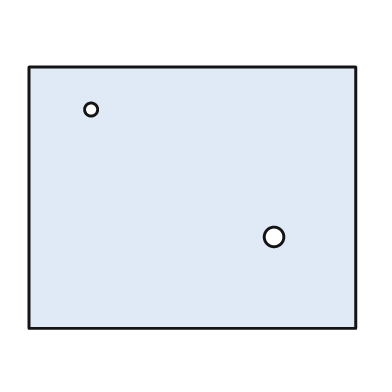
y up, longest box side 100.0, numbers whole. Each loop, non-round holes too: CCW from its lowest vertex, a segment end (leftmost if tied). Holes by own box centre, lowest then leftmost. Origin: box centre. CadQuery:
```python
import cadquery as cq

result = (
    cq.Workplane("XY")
    .moveTo(-50.0, -40.0)
    .lineTo(50.0, -40.0)
    .lineTo(50.0, 40.0)
    .lineTo(-50.0, 40.0)
    .close()
    .moveTo(25.0, -12.0)
    .circle(3.0)
    .moveTo(-31.0, 27.0)
    .circle(2.0)
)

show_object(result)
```